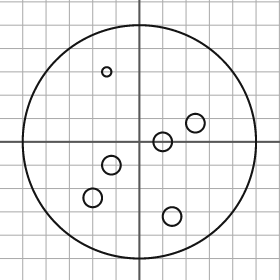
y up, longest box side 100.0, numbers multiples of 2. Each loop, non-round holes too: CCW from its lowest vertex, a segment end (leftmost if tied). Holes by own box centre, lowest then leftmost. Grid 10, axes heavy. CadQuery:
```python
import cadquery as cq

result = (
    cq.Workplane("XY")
    .moveTo(0.0, 0.0)
    .circle(50.0)
    .moveTo(14.0, -32.0)
    .circle(4.0)
    .moveTo(-20.0, -24.0)
    .circle(4.0)
    .moveTo(-12.0, -10.0)
    .circle(4.0)
    .moveTo(10.0, 0.0)
    .circle(4.0)
    .moveTo(24.0, 8.0)
    .circle(4.0)
    .moveTo(-14.0, 30.0)
    .circle(2.0)
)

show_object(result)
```